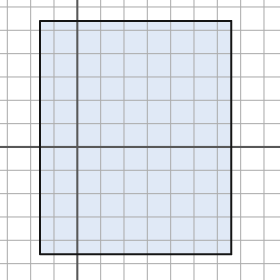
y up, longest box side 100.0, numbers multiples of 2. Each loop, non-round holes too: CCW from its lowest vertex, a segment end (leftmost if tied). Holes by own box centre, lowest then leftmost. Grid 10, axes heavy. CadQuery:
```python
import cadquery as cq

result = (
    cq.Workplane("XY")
    .moveTo(-16.0, -46.0)
    .lineTo(66.0, -46.0)
    .lineTo(66.0, 54.0)
    .lineTo(-16.0, 54.0)
    .close()
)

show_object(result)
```